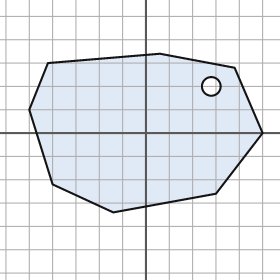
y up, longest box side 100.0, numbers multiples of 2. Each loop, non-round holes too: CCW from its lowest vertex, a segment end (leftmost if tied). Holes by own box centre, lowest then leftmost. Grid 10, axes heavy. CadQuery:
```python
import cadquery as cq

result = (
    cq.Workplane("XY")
    .moveTo(-14.0, -34.0)
    .lineTo(30.0, -26.0)
    .lineTo(50.0, 0.0)
    .lineTo(38.0, 28.0)
    .lineTo(6.0, 34.0)
    .lineTo(-42.0, 30.0)
    .lineTo(-50.0, 10.0)
    .lineTo(-40.0, -22.0)
    .close()
    .moveTo(28.0, 20.0)
    .circle(4.0)
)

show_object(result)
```